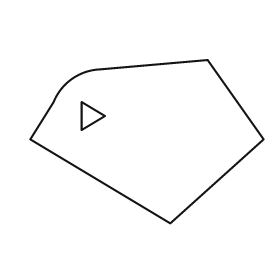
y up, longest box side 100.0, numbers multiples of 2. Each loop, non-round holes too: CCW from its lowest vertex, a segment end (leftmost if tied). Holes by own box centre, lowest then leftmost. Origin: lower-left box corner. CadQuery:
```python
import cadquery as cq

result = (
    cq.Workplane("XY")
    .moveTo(60.0, 0.0)
    .lineTo(100.0, 36.0)
    .lineTo(76.0, 70.0)
    .lineTo(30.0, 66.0)
    .threePointArc((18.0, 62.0), (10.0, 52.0))
    .lineTo(0.0, 36.0)
    .close()
    .moveTo(22.0, 40.0)
    .lineTo(32.0, 46.0)
    .lineTo(22.0, 52.0)
    .close()
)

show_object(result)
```